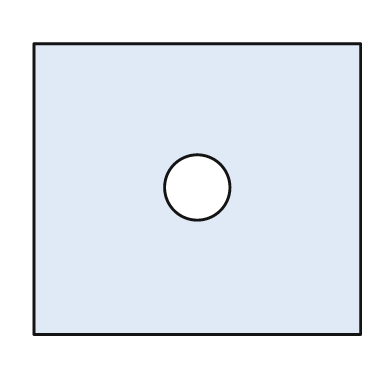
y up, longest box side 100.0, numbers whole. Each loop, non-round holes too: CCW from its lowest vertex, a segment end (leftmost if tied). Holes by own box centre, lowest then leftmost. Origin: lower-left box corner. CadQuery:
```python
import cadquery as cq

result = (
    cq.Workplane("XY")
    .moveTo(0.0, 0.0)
    .lineTo(100.0, 0.0)
    .lineTo(100.0, 89.0)
    .lineTo(0.0, 89.0)
    .close()
    .moveTo(50.0, 45.0)
    .circle(10.0)
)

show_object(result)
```